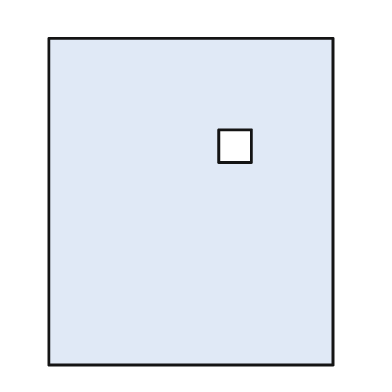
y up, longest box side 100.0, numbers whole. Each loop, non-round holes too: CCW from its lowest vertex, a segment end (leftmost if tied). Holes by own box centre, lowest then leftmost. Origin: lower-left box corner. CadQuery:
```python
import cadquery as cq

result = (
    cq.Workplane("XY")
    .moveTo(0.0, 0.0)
    .lineTo(87.0, 0.0)
    .lineTo(87.0, 100.0)
    .lineTo(0.0, 100.0)
    .close()
    .moveTo(52.0, 62.0)
    .lineTo(62.0, 62.0)
    .lineTo(62.0, 72.0)
    .lineTo(52.0, 72.0)
    .close()
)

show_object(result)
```